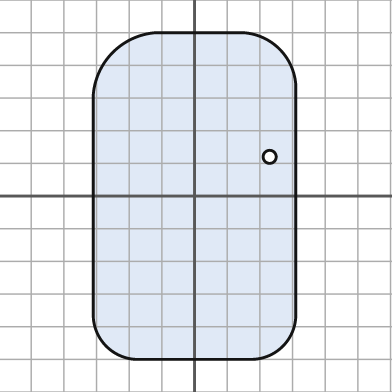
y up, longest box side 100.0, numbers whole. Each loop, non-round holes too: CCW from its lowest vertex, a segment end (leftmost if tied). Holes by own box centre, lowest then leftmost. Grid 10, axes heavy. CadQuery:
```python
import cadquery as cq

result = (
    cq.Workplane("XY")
    .moveTo(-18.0, -50.0)
    .lineTo(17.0, -50.0)
    .threePointArc((27.0, -46.0), (31.0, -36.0))
    .lineTo(31.0, 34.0)
    .threePointArc((26.0, 45.0), (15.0, 50.0))
    .lineTo(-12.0, 50.0)
    .threePointArc((-25.0, 44.0), (-31.0, 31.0))
    .lineTo(-31.0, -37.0)
    .threePointArc((-27.0, -46.0), (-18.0, -50.0))
    .close()
    .moveTo(23.0, 12.0)
    .circle(2.0)
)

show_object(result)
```